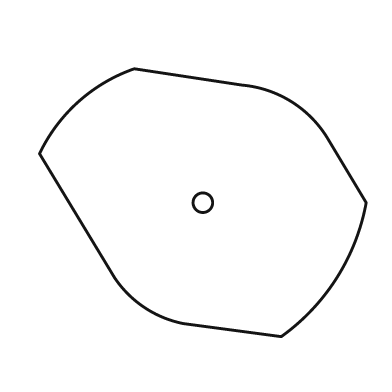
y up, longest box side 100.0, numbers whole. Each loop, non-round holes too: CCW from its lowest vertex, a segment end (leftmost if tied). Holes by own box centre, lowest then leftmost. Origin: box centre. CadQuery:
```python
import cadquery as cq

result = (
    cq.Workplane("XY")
    .moveTo(24.0, -41.0)
    .threePointArc((41.0, -23.0), (50.0, 0.0))
    .lineTo(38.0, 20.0)
    .threePointArc((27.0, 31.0), (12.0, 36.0))
    .lineTo(-21.0, 41.0)
    .threePointArc((-38.0, 31.0), (-50.0, 15.0))
    .lineTo(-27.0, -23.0)
    .threePointArc((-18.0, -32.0), (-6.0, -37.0))
    .close()
    .moveTo(0.0, 0.0)
    .circle(3.0)
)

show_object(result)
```